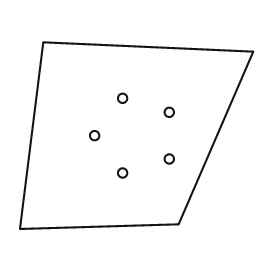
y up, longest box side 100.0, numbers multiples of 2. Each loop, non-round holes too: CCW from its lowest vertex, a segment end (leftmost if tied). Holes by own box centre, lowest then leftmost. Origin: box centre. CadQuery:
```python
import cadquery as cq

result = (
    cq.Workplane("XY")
    .moveTo(-50.0, -40.0)
    .lineTo(18.0, -38.0)
    .lineTo(50.0, 36.0)
    .lineTo(-40.0, 40.0)
    .close()
    .moveTo(-6.0, -16.0)
    .circle(2.0)
    .moveTo(14.0, -10.0)
    .circle(2.0)
    .moveTo(-18.0, 0.0)
    .circle(2.0)
    .moveTo(14.0, 10.0)
    .circle(2.0)
    .moveTo(-6.0, 16.0)
    .circle(2.0)
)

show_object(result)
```